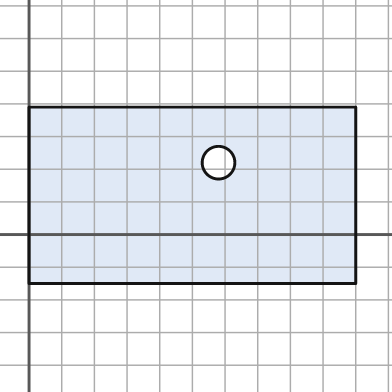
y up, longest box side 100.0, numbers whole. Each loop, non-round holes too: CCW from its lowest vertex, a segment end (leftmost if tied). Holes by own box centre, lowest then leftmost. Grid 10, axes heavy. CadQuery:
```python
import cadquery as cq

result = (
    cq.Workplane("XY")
    .moveTo(0.0, -15.0)
    .lineTo(100.0, -15.0)
    .lineTo(100.0, 39.0)
    .lineTo(0.0, 39.0)
    .close()
    .moveTo(58.0, 22.0)
    .circle(5.0)
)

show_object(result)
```